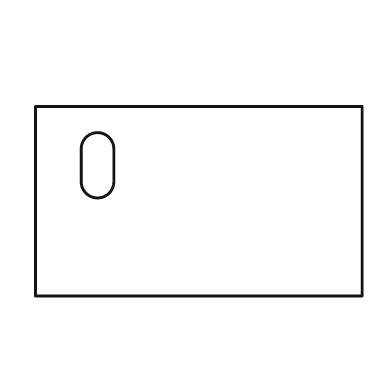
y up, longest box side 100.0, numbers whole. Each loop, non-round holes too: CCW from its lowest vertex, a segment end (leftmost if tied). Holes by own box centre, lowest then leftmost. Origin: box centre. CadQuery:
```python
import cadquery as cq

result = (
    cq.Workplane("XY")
    .moveTo(-50.0, -29.0)
    .lineTo(50.0, -29.0)
    .lineTo(50.0, 29.0)
    .lineTo(-50.0, 29.0)
    .close()
    .moveTo(-36.0, 6.0)
    .threePointArc((-31.0, 1.0), (-26.0, 6.0))
    .lineTo(-26.0, 16.0)
    .threePointArc((-31.0, 21.0), (-36.0, 16.0))
    .close()
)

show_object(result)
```